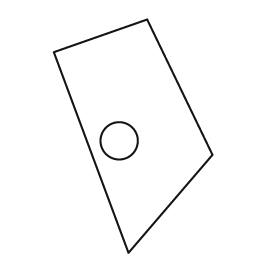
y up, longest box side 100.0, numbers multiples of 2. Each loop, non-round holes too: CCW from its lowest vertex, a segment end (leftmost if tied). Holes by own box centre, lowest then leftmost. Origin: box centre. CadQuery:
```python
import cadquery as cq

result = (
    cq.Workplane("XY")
    .moveTo(-2.0, -50.0)
    .lineTo(34.0, -8.0)
    .lineTo(6.0, 50.0)
    .lineTo(-34.0, 36.0)
    .close()
    .moveTo(-6.0, -2.0)
    .circle(8.0)
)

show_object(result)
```